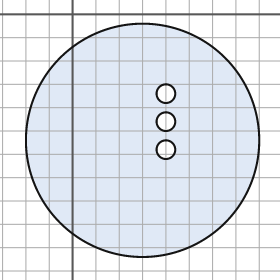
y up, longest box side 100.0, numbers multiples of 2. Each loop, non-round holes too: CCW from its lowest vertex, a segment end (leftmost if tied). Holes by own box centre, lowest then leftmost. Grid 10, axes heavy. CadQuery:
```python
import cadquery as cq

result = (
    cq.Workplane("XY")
    .moveTo(30.0, -54.0)
    .circle(50.0)
    .moveTo(40.0, -58.0)
    .circle(4.0)
    .moveTo(40.0, -46.0)
    .circle(4.0)
    .moveTo(40.0, -34.0)
    .circle(4.0)
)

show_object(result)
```